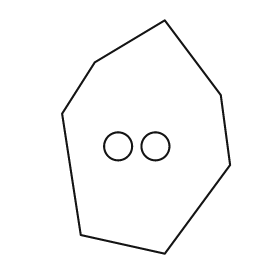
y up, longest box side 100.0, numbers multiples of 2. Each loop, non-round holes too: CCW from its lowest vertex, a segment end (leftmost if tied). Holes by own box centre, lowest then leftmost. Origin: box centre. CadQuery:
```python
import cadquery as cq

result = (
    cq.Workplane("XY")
    .moveTo(8.0, -50.0)
    .lineTo(36.0, -12.0)
    .lineTo(32.0, 18.0)
    .lineTo(8.0, 50.0)
    .lineTo(-22.0, 32.0)
    .lineTo(-36.0, 10.0)
    .lineTo(-28.0, -42.0)
    .close()
    .moveTo(-12.0, -4.0)
    .circle(6.0)
    .moveTo(4.0, -4.0)
    .circle(6.0)
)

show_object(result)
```